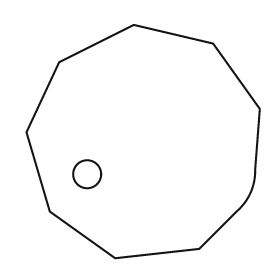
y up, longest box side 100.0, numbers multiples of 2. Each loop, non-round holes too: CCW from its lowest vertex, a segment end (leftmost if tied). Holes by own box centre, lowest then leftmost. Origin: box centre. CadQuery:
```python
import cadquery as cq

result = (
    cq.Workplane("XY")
    .moveTo(-12.0, -50.0)
    .lineTo(24.0, -46.0)
    .lineTo(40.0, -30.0)
    .threePointArc((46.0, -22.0), (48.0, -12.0))
    .lineTo(50.0, 14.0)
    .lineTo(30.0, 42.0)
    .lineTo(-4.0, 50.0)
    .lineTo(-36.0, 34.0)
    .lineTo(-50.0, 4.0)
    .lineTo(-40.0, -30.0)
    .close()
    .moveTo(-24.0, -14.0)
    .circle(6.0)
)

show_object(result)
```